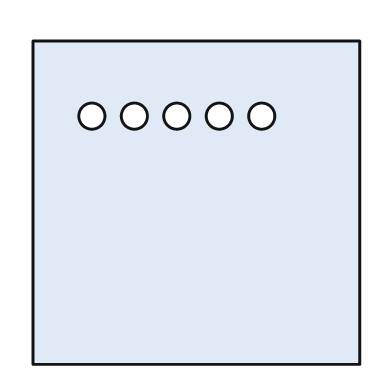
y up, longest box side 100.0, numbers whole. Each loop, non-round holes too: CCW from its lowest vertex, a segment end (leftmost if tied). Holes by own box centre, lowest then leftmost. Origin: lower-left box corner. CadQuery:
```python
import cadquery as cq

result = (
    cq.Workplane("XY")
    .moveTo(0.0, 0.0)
    .lineTo(100.0, 0.0)
    .lineTo(100.0, 99.0)
    .lineTo(0.0, 99.0)
    .close()
    .moveTo(18.0, 76.0)
    .circle(4.0)
    .moveTo(31.0, 76.0)
    .circle(4.0)
    .moveTo(44.0, 76.0)
    .circle(4.0)
    .moveTo(57.0, 76.0)
    .circle(4.0)
    .moveTo(70.0, 76.0)
    .circle(4.0)
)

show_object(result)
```